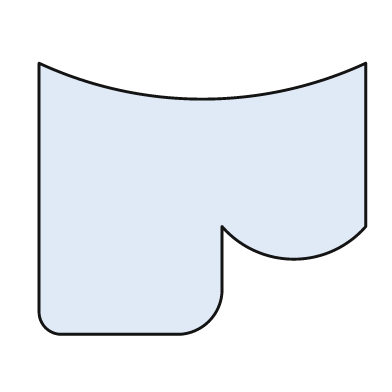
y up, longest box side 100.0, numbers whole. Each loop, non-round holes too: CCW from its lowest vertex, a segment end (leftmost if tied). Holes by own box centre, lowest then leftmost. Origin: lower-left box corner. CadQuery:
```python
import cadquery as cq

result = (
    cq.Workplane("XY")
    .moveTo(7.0, 0.0)
    .lineTo(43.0, 0.0)
    .threePointArc((52.0, 4.0), (56.0, 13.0))
    .lineTo(56.0, 33.0)
    .threePointArc((78.0, 23.0), (100.0, 33.0))
    .lineTo(100.0, 83.0)
    .threePointArc((50.0, 72.0), (0.0, 83.0))
    .lineTo(0.0, 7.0)
    .threePointArc((2.0, 2.0), (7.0, 0.0))
    .close()
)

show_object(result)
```